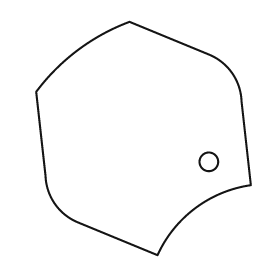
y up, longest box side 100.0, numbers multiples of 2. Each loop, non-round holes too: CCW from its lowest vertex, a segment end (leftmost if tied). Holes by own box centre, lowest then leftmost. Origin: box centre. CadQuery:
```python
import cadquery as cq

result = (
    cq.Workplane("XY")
    .moveTo(6.0, -50.0)
    .threePointArc((22.0, -30.0), (46.0, -20.0))
    .lineTo(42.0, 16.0)
    .threePointArc((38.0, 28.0), (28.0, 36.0))
    .lineTo(-6.0, 50.0)
    .threePointArc((-28.0, 38.0), (-46.0, 20.0))
    .lineTo(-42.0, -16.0)
    .threePointArc((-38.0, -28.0), (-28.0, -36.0))
    .close()
    .moveTo(28.0, -10.0)
    .circle(4.0)
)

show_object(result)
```